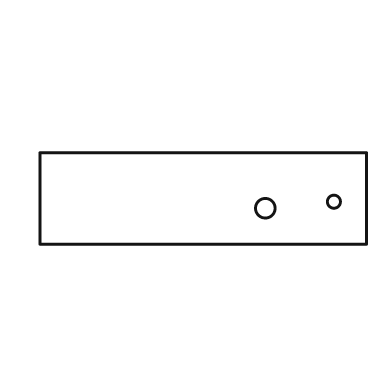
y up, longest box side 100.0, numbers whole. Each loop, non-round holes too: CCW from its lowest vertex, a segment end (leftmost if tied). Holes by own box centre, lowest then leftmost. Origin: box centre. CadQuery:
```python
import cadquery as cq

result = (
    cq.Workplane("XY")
    .moveTo(-50.0, -14.0)
    .lineTo(50.0, -14.0)
    .lineTo(50.0, 14.0)
    .lineTo(-50.0, 14.0)
    .close()
    .moveTo(19.0, -3.0)
    .circle(3.0)
    .moveTo(40.0, -1.0)
    .circle(2.0)
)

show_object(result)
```